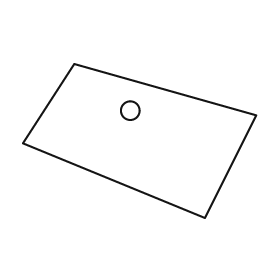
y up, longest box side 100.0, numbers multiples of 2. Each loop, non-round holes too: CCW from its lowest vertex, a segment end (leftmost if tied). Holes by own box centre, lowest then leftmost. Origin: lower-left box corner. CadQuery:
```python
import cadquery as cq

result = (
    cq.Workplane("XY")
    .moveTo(78.0, 0.0)
    .lineTo(100.0, 44.0)
    .lineTo(22.0, 66.0)
    .lineTo(0.0, 32.0)
    .close()
    .moveTo(46.0, 46.0)
    .circle(4.0)
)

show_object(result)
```